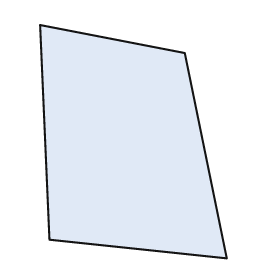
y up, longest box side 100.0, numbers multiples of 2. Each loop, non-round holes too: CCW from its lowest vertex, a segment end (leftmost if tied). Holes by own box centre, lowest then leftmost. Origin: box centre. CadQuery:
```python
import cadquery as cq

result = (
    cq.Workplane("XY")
    .moveTo(40.0, -50.0)
    .lineTo(22.0, 38.0)
    .lineTo(-40.0, 50.0)
    .lineTo(-36.0, -42.0)
    .close()
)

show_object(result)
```